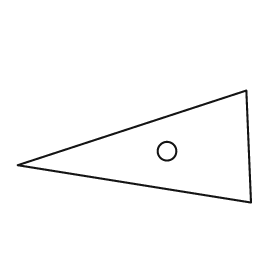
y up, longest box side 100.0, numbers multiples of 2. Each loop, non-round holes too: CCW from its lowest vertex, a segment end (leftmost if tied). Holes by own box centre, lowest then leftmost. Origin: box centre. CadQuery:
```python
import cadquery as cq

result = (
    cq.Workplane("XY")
    .moveTo(50.0, -24.0)
    .lineTo(48.0, 24.0)
    .lineTo(-50.0, -8.0)
    .close()
    .moveTo(14.0, -2.0)
    .circle(4.0)
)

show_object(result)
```